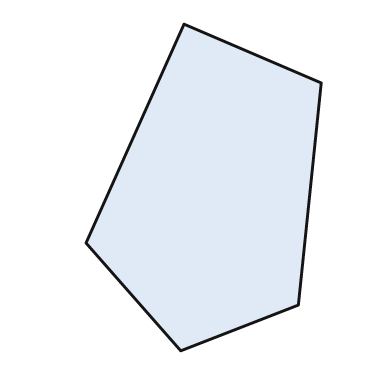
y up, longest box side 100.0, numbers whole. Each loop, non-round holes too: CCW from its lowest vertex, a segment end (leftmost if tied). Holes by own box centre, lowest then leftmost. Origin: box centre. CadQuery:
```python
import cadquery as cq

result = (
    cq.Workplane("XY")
    .moveTo(-7.0, -50.0)
    .lineTo(29.0, -36.0)
    .lineTo(36.0, 32.0)
    .lineTo(-6.0, 50.0)
    .lineTo(-36.0, -17.0)
    .close()
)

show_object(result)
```